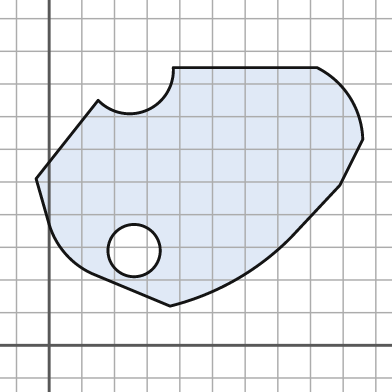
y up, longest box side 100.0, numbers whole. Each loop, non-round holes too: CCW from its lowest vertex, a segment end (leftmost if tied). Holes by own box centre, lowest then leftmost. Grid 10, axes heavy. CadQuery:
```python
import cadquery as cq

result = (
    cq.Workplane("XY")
    .moveTo(37.0, 12.0)
    .threePointArc((57.0, 20.0), (74.0, 33.0))
    .lineTo(89.0, 49.0)
    .lineTo(96.0, 63.0)
    .threePointArc((92.0, 76.0), (82.0, 85.0))
    .lineTo(38.0, 85.0)
    .threePointArc((30.0, 72.0), (15.0, 75.0))
    .lineTo(-4.0, 51.0)
    .lineTo(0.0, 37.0)
    .threePointArc((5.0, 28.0), (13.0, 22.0))
    .close()
    .moveTo(26.0, 29.0)
    .circle(8.0)
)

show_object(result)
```